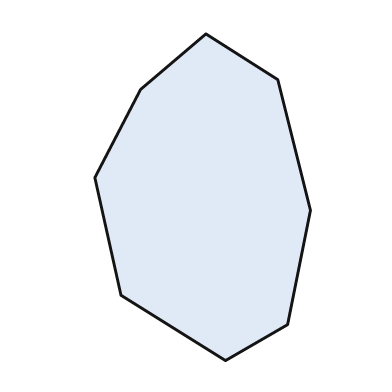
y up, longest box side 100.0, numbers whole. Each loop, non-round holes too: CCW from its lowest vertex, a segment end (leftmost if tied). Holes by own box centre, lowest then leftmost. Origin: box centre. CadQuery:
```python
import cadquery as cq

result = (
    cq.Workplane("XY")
    .moveTo(7.0, -50.0)
    .lineTo(26.0, -39.0)
    .lineTo(33.0, -4.0)
    .lineTo(23.0, 36.0)
    .lineTo(1.0, 50.0)
    .lineTo(-19.0, 33.0)
    .lineTo(-33.0, 6.0)
    .lineTo(-25.0, -30.0)
    .close()
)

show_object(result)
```